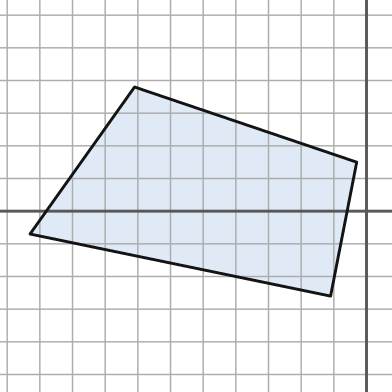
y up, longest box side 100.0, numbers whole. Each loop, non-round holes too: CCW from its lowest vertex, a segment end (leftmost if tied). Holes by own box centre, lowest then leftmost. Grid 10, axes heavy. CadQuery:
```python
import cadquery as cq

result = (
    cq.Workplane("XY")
    .moveTo(-11.0, -26.0)
    .lineTo(-3.0, 15.0)
    .lineTo(-71.0, 38.0)
    .lineTo(-103.0, -7.0)
    .close()
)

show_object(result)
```